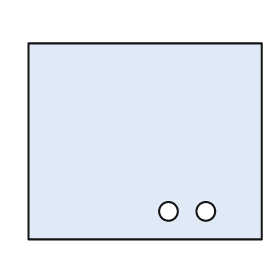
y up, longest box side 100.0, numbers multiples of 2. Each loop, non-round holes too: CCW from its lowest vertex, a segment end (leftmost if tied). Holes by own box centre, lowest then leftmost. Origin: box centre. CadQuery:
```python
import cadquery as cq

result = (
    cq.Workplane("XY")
    .moveTo(-50.0, -42.0)
    .lineTo(50.0, -42.0)
    .lineTo(50.0, 42.0)
    .lineTo(-50.0, 42.0)
    .close()
    .moveTo(10.0, -30.0)
    .circle(4.0)
    .moveTo(26.0, -30.0)
    .circle(4.0)
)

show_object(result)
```